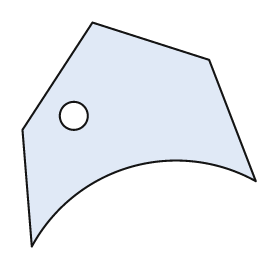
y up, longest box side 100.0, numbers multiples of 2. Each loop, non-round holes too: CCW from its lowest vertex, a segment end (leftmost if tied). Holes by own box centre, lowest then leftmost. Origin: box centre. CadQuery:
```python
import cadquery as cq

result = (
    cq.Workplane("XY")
    .moveTo(-46.0, -48.0)
    .threePointArc((-4.0, -14.0), (50.0, -20.0))
    .lineTo(30.0, 32.0)
    .lineTo(-20.0, 48.0)
    .lineTo(-50.0, 2.0)
    .close()
    .moveTo(-28.0, 8.0)
    .circle(6.0)
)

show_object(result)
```